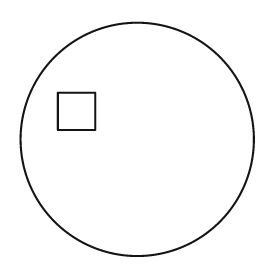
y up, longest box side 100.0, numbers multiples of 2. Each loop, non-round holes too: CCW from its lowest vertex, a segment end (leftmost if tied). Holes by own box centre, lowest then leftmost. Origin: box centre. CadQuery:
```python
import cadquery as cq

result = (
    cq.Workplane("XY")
    .moveTo(0.0, 0.0)
    .circle(50.0)
    .moveTo(-34.0, 4.0)
    .lineTo(-18.0, 4.0)
    .lineTo(-18.0, 20.0)
    .lineTo(-34.0, 20.0)
    .close()
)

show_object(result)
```